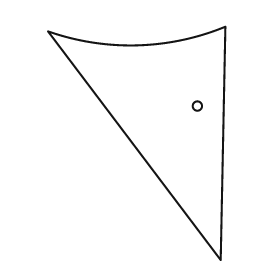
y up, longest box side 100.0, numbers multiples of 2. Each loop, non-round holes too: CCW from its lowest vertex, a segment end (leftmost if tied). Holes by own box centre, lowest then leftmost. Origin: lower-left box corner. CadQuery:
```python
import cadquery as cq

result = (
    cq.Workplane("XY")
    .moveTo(74.0, 0.0)
    .lineTo(76.0, 100.0)
    .threePointArc((38.0, 92.0), (0.0, 98.0))
    .close()
    .moveTo(64.0, 66.0)
    .circle(2.0)
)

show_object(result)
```